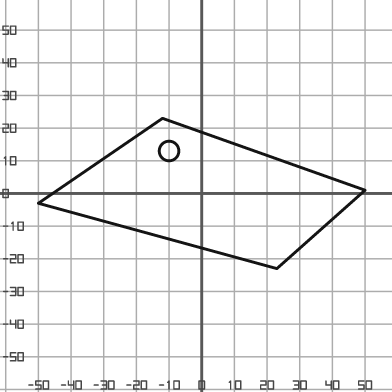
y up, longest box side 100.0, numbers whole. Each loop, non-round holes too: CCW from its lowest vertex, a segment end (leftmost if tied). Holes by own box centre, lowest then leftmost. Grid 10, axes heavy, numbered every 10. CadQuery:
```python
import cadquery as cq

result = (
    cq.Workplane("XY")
    .moveTo(23.0, -23.0)
    .lineTo(50.0, 1.0)
    .lineTo(-12.0, 23.0)
    .lineTo(-50.0, -3.0)
    .close()
    .moveTo(-10.0, 13.0)
    .circle(3.0)
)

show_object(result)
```